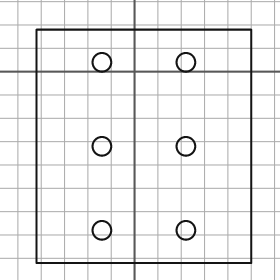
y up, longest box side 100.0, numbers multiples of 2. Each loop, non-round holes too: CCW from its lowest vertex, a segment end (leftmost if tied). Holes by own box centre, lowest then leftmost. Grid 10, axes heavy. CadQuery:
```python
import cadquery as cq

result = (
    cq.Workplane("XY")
    .moveTo(-42.0, -82.0)
    .lineTo(50.0, -82.0)
    .lineTo(50.0, 18.0)
    .lineTo(-42.0, 18.0)
    .close()
    .moveTo(-14.0, -68.0)
    .circle(4.0)
    .moveTo(22.0, -68.0)
    .circle(4.0)
    .moveTo(-14.0, -32.0)
    .circle(4.0)
    .moveTo(22.0, -32.0)
    .circle(4.0)
    .moveTo(-14.0, 4.0)
    .circle(4.0)
    .moveTo(22.0, 4.0)
    .circle(4.0)
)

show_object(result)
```